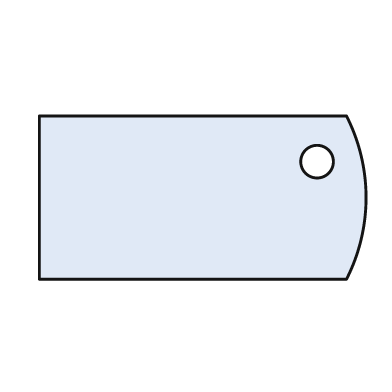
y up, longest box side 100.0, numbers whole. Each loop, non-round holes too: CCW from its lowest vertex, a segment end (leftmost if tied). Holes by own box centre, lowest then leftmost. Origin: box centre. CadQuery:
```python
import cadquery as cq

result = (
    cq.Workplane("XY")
    .moveTo(-50.0, -25.0)
    .lineTo(44.0, -25.0)
    .threePointArc((50.0, 0.0), (44.0, 25.0))
    .lineTo(-50.0, 25.0)
    .close()
    .moveTo(35.0, 11.0)
    .circle(5.0)
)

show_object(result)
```